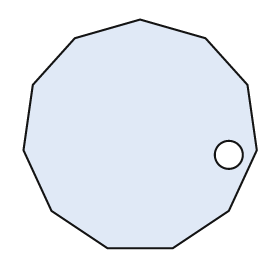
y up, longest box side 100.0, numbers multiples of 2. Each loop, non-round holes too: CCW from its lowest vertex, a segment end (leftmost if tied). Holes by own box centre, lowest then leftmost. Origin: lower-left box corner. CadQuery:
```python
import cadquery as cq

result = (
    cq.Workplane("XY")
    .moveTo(36.0, 0.0)
    .lineTo(64.0, 0.0)
    .lineTo(88.0, 16.0)
    .lineTo(100.0, 42.0)
    .lineTo(96.0, 70.0)
    .lineTo(78.0, 90.0)
    .lineTo(50.0, 98.0)
    .lineTo(22.0, 90.0)
    .lineTo(4.0, 70.0)
    .lineTo(0.0, 42.0)
    .lineTo(12.0, 16.0)
    .close()
    .moveTo(88.0, 40.0)
    .circle(6.0)
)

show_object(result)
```